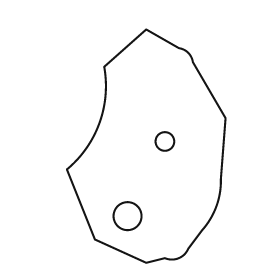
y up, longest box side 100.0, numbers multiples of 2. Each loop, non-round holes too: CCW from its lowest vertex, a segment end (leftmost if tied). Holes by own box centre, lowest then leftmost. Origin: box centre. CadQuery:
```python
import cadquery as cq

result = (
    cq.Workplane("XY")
    .moveTo(0.0, -50.0)
    .lineTo(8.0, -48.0)
    .threePointArc((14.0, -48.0), (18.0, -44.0))
    .lineTo(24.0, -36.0)
    .threePointArc((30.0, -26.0), (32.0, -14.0))
    .lineTo(34.0, 12.0)
    .lineTo(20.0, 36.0)
    .threePointArc((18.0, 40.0), (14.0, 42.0))
    .lineTo(0.0, 50.0)
    .lineTo(-18.0, 34.0)
    .threePointArc((-20.0, 10.0), (-34.0, -10.0))
    .lineTo(-22.0, -40.0)
    .close()
    .moveTo(-8.0, -30.0)
    .circle(6.0)
    .moveTo(8.0, 2.0)
    .circle(4.0)
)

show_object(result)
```